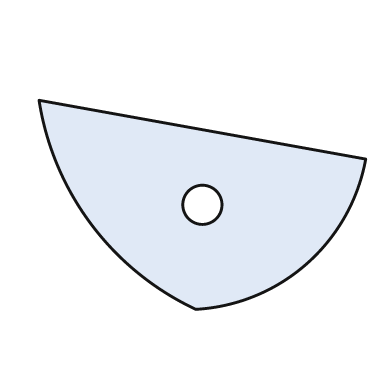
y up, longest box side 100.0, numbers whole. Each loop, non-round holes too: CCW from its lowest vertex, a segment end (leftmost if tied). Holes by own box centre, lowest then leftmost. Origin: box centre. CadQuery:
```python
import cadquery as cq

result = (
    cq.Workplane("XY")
    .moveTo(-2.0, -32.0)
    .threePointArc((32.0, -18.0), (50.0, 14.0))
    .lineTo(-50.0, 32.0)
    .threePointArc((-34.0, -6.0), (-2.0, -32.0))
    .close()
    .moveTo(0.0, 0.0)
    .circle(6.0)
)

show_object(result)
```